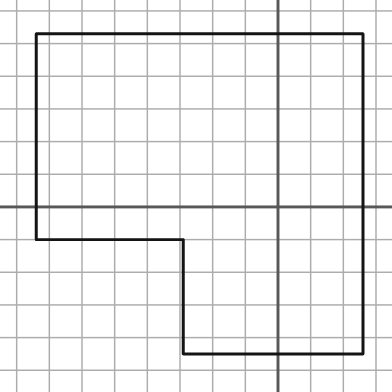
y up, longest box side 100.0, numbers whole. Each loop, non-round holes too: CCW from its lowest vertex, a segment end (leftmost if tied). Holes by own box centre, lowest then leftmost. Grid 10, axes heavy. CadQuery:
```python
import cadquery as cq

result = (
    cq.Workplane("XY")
    .moveTo(-29.0, -45.0)
    .lineTo(26.0, -45.0)
    .lineTo(26.0, 53.0)
    .lineTo(-74.0, 53.0)
    .lineTo(-74.0, -10.0)
    .lineTo(-29.0, -10.0)
    .close()
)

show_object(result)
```